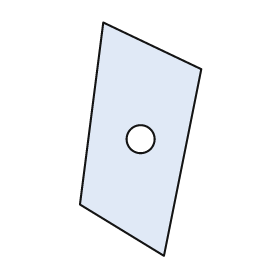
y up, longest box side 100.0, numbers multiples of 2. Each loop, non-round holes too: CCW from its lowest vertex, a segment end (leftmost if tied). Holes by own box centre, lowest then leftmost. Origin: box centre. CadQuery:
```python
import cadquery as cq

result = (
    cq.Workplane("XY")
    .moveTo(10.0, -50.0)
    .lineTo(26.0, 30.0)
    .lineTo(-16.0, 50.0)
    .lineTo(-26.0, -28.0)
    .close()
    .moveTo(0.0, 0.0)
    .circle(6.0)
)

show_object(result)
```